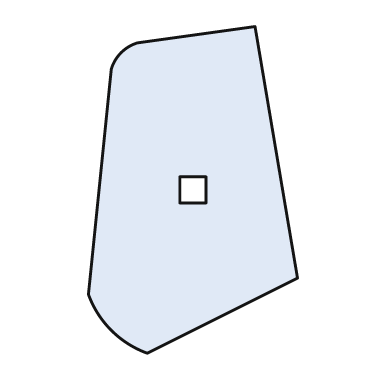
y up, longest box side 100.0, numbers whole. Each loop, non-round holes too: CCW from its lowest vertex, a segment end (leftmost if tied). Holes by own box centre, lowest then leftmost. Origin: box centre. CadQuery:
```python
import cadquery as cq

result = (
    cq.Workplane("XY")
    .moveTo(-14.0, -50.0)
    .lineTo(32.0, -27.0)
    .lineTo(19.0, 50.0)
    .lineTo(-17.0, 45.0)
    .threePointArc((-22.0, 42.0), (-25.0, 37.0))
    .lineTo(-32.0, -32.0)
    .threePointArc((-25.0, -43.0), (-14.0, -50.0))
    .close()
    .moveTo(-4.0, -4.0)
    .lineTo(4.0, -4.0)
    .lineTo(4.0, 4.0)
    .lineTo(-4.0, 4.0)
    .close()
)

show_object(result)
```